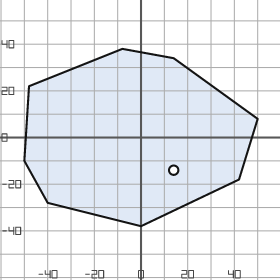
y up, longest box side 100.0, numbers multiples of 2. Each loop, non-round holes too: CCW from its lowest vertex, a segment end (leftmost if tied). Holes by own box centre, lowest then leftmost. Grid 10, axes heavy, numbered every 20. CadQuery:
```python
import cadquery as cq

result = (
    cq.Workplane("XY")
    .moveTo(0.0, -38.0)
    .lineTo(42.0, -18.0)
    .lineTo(50.0, 8.0)
    .lineTo(14.0, 34.0)
    .lineTo(-8.0, 38.0)
    .lineTo(-48.0, 22.0)
    .lineTo(-50.0, -10.0)
    .lineTo(-40.0, -28.0)
    .close()
    .moveTo(14.0, -14.0)
    .circle(2.0)
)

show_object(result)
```